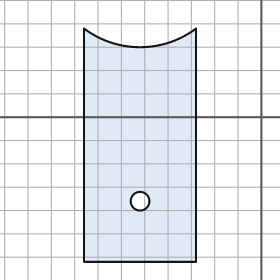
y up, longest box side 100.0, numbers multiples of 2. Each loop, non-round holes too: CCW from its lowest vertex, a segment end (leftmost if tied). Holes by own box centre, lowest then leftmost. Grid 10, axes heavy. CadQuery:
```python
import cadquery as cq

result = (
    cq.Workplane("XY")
    .moveTo(-76.0, -62.0)
    .lineTo(-28.0, -62.0)
    .lineTo(-28.0, 38.0)
    .threePointArc((-52.0, 30.0), (-76.0, 38.0))
    .close()
    .moveTo(-52.0, -36.0)
    .circle(4.0)
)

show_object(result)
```